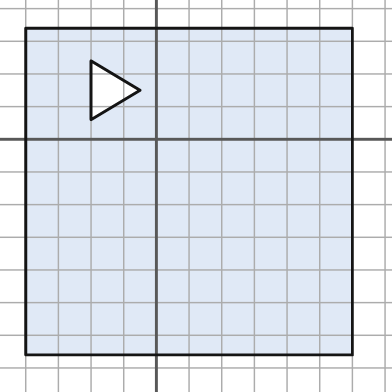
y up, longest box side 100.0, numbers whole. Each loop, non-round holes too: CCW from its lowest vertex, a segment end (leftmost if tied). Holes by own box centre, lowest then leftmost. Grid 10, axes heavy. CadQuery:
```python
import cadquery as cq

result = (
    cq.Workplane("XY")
    .moveTo(-40.0, -66.0)
    .lineTo(60.0, -66.0)
    .lineTo(60.0, 34.0)
    .lineTo(-40.0, 34.0)
    .close()
    .moveTo(-20.0, 6.0)
    .lineTo(-5.0, 15.0)
    .lineTo(-20.0, 24.0)
    .close()
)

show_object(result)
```